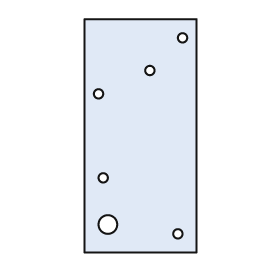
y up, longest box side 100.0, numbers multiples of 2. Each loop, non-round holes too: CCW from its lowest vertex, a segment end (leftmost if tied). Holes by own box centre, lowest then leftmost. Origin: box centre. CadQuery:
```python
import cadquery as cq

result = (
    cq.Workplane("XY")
    .moveTo(-24.0, -50.0)
    .lineTo(24.0, -50.0)
    .lineTo(24.0, 50.0)
    .lineTo(-24.0, 50.0)
    .close()
    .moveTo(16.0, -42.0)
    .circle(2.0)
    .moveTo(-14.0, -38.0)
    .circle(4.0)
    .moveTo(-16.0, -18.0)
    .circle(2.0)
    .moveTo(-18.0, 18.0)
    .circle(2.0)
    .moveTo(4.0, 28.0)
    .circle(2.0)
    .moveTo(18.0, 42.0)
    .circle(2.0)
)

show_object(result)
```